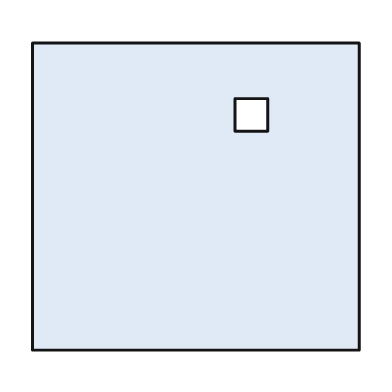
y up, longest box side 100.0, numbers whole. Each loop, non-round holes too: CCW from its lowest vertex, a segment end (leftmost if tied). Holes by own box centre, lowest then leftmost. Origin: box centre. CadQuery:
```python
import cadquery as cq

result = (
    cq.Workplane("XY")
    .moveTo(-50.0, -47.0)
    .lineTo(50.0, -47.0)
    .lineTo(50.0, 47.0)
    .lineTo(-50.0, 47.0)
    .close()
    .moveTo(12.0, 20.0)
    .lineTo(22.0, 20.0)
    .lineTo(22.0, 30.0)
    .lineTo(12.0, 30.0)
    .close()
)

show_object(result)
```